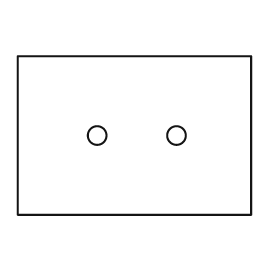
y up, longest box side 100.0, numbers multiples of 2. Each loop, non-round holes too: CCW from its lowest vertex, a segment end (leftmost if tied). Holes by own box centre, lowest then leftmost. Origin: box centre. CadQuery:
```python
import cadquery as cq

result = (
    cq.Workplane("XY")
    .moveTo(-50.0, -34.0)
    .lineTo(50.0, -34.0)
    .lineTo(50.0, 34.0)
    .lineTo(-50.0, 34.0)
    .close()
    .moveTo(-16.0, 0.0)
    .circle(4.0)
    .moveTo(18.0, 0.0)
    .circle(4.0)
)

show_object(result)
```